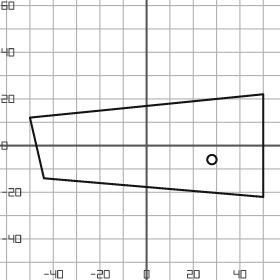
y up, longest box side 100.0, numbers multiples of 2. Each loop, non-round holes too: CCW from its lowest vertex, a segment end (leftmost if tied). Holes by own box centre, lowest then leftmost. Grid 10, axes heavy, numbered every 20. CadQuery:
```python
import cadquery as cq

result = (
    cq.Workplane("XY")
    .moveTo(50.0, -22.0)
    .lineTo(50.0, 22.0)
    .lineTo(-50.0, 12.0)
    .lineTo(-44.0, -14.0)
    .close()
    .moveTo(28.0, -6.0)
    .circle(2.0)
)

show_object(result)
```